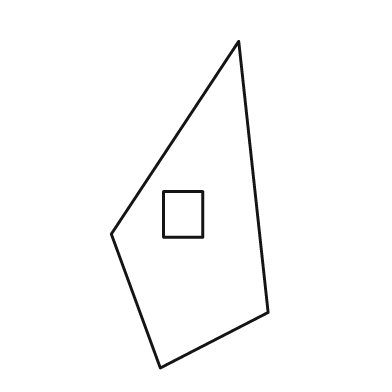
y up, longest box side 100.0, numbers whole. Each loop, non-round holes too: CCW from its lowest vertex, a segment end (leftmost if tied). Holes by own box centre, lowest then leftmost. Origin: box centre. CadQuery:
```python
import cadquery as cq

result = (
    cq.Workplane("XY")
    .moveTo(-9.0, -50.0)
    .lineTo(24.0, -33.0)
    .lineTo(15.0, 50.0)
    .lineTo(-24.0, -9.0)
    .close()
    .moveTo(-8.0, -10.0)
    .lineTo(4.0, -10.0)
    .lineTo(4.0, 4.0)
    .lineTo(-8.0, 4.0)
    .close()
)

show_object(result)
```